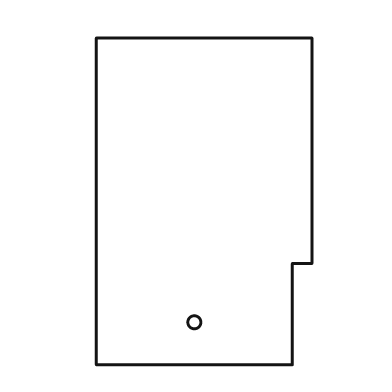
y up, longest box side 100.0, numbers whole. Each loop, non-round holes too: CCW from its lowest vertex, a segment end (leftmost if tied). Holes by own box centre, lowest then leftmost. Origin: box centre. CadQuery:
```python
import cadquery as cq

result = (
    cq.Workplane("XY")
    .moveTo(-33.0, -50.0)
    .lineTo(27.0, -50.0)
    .lineTo(27.0, -19.0)
    .lineTo(33.0, -19.0)
    .lineTo(33.0, 50.0)
    .lineTo(-33.0, 50.0)
    .close()
    .moveTo(-3.0, -37.0)
    .circle(2.0)
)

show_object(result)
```